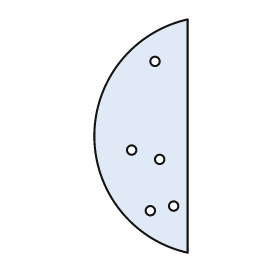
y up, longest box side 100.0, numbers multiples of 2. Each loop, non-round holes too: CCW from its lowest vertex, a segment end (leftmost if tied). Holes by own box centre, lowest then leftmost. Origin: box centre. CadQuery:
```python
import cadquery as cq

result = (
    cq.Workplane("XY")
    .moveTo(20.0, -50.0)
    .lineTo(20.0, 50.0)
    .threePointArc((-20.0, 0.0), (20.0, -50.0))
    .close()
    .moveTo(4.0, -32.0)
    .circle(2.0)
    .moveTo(14.0, -30.0)
    .circle(2.0)
    .moveTo(8.0, -10.0)
    .circle(2.0)
    .moveTo(-4.0, -6.0)
    .circle(2.0)
    .moveTo(6.0, 32.0)
    .circle(2.0)
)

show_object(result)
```